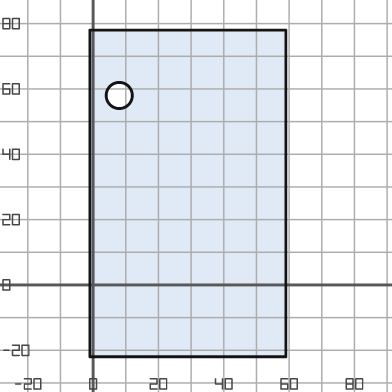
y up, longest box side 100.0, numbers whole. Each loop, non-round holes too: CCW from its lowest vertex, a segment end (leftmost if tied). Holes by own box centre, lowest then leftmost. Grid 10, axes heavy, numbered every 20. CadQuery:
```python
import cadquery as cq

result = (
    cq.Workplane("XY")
    .moveTo(-1.0, -22.0)
    .lineTo(59.0, -22.0)
    .lineTo(59.0, 78.0)
    .lineTo(-1.0, 78.0)
    .close()
    .moveTo(8.0, 58.0)
    .circle(4.0)
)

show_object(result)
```